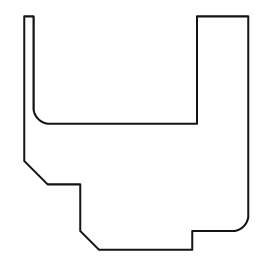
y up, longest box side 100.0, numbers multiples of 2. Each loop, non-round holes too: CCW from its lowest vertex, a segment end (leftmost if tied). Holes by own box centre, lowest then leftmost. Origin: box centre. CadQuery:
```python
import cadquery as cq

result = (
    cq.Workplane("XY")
    .moveTo(-16.0, -50.0)
    .lineTo(24.0, -50.0)
    .lineTo(24.0, -42.0)
    .lineTo(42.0, -42.0)
    .threePointArc((46.0, -40.0), (48.0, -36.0))
    .lineTo(48.0, 50.0)
    .lineTo(26.0, 50.0)
    .lineTo(26.0, 4.0)
    .lineTo(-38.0, 4.0)
    .threePointArc((-42.0, 6.0), (-44.0, 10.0))
    .lineTo(-44.0, 50.0)
    .lineTo(-48.0, 50.0)
    .lineTo(-48.0, -12.0)
    .lineTo(-38.0, -22.0)
    .lineTo(-24.0, -22.0)
    .lineTo(-24.0, -42.0)
    .close()
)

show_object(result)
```